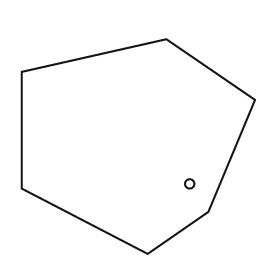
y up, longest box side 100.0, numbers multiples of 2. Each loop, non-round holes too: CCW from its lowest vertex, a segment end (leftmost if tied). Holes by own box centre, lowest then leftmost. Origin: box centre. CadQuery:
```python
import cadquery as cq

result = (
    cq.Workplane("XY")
    .moveTo(4.0, -46.0)
    .lineTo(30.0, -28.0)
    .lineTo(50.0, 20.0)
    .lineTo(12.0, 46.0)
    .lineTo(-50.0, 32.0)
    .lineTo(-50.0, -18.0)
    .close()
    .moveTo(22.0, -16.0)
    .circle(2.0)
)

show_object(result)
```